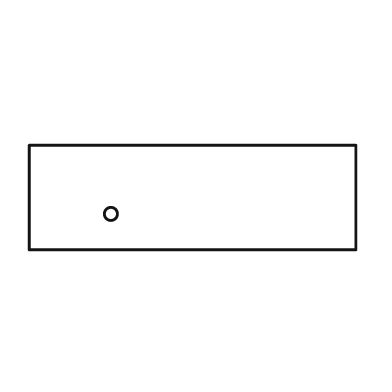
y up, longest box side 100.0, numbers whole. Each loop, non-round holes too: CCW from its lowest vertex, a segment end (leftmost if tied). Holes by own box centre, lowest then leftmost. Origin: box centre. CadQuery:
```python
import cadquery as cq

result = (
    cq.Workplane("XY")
    .moveTo(-50.0, -16.0)
    .lineTo(50.0, -16.0)
    .lineTo(50.0, 16.0)
    .lineTo(-50.0, 16.0)
    .close()
    .moveTo(-25.0, -5.0)
    .circle(2.0)
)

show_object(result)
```